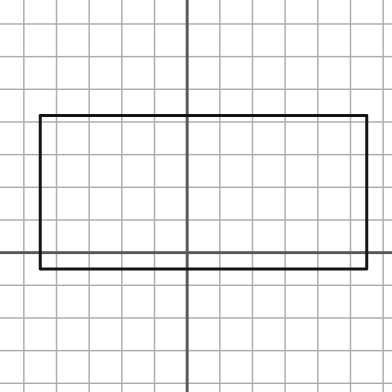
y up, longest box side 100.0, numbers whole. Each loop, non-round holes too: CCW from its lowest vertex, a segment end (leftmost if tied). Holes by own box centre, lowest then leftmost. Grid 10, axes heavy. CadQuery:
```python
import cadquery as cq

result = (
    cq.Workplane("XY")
    .moveTo(-45.0, -5.0)
    .lineTo(55.0, -5.0)
    .lineTo(55.0, 42.0)
    .lineTo(-45.0, 42.0)
    .close()
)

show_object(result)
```